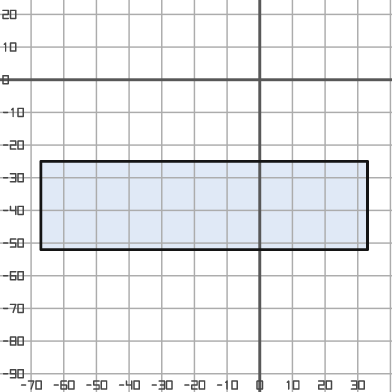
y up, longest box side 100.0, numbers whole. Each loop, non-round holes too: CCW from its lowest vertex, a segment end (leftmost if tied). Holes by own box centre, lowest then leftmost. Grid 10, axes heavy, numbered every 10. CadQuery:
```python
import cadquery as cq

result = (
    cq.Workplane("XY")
    .moveTo(-67.0, -52.0)
    .lineTo(33.0, -52.0)
    .lineTo(33.0, -25.0)
    .lineTo(-67.0, -25.0)
    .close()
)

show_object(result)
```